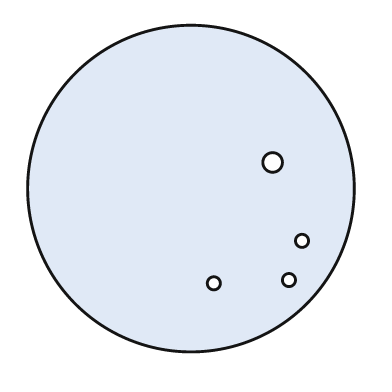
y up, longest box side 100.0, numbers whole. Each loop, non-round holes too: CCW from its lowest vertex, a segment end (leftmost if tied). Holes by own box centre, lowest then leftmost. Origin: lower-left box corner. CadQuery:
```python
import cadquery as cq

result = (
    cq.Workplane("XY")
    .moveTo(50.0, 50.0)
    .circle(50.0)
    .moveTo(57.0, 21.0)
    .circle(2.0)
    .moveTo(80.0, 22.0)
    .circle(2.0)
    .moveTo(84.0, 34.0)
    .circle(2.0)
    .moveTo(75.0, 58.0)
    .circle(3.0)
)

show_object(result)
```